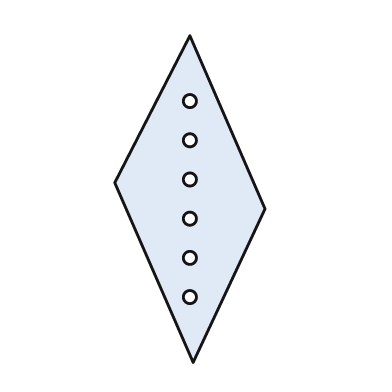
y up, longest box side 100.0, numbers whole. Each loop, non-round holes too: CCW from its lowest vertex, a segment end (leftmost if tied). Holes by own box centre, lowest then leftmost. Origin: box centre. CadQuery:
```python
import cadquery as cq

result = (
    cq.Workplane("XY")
    .moveTo(1.0, -50.0)
    .lineTo(23.0, -3.0)
    .lineTo(0.0, 50.0)
    .lineTo(-23.0, 5.0)
    .close()
    .moveTo(0.0, -30.0)
    .circle(2.0)
    .moveTo(0.0, -18.0)
    .circle(2.0)
    .moveTo(0.0, -6.0)
    .circle(2.0)
    .moveTo(0.0, 6.0)
    .circle(2.0)
    .moveTo(0.0, 18.0)
    .circle(2.0)
    .moveTo(0.0, 30.0)
    .circle(2.0)
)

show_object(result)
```